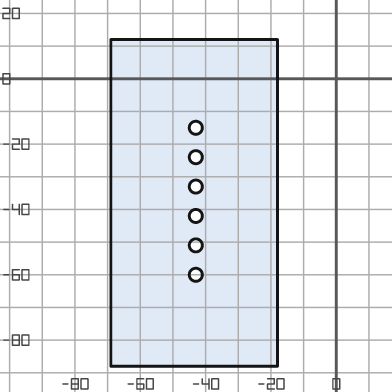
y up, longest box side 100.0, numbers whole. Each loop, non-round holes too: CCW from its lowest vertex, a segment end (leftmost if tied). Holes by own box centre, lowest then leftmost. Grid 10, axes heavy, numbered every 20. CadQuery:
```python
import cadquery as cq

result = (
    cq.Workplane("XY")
    .moveTo(-69.0, -88.0)
    .lineTo(-18.0, -88.0)
    .lineTo(-18.0, 12.0)
    .lineTo(-69.0, 12.0)
    .close()
    .moveTo(-43.0, -60.0)
    .circle(2.0)
    .moveTo(-43.0, -51.0)
    .circle(2.0)
    .moveTo(-43.0, -42.0)
    .circle(2.0)
    .moveTo(-43.0, -33.0)
    .circle(2.0)
    .moveTo(-43.0, -24.0)
    .circle(2.0)
    .moveTo(-43.0, -15.0)
    .circle(2.0)
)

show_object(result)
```